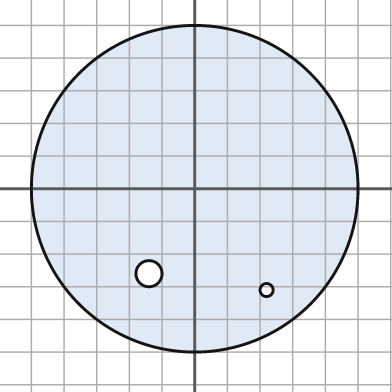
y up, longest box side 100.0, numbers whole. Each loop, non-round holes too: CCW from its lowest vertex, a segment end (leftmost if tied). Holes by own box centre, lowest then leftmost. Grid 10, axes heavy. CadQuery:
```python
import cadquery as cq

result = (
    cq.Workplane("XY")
    .moveTo(0.0, 0.0)
    .circle(50.0)
    .moveTo(22.0, -31.0)
    .circle(2.0)
    .moveTo(-14.0, -26.0)
    .circle(4.0)
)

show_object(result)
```